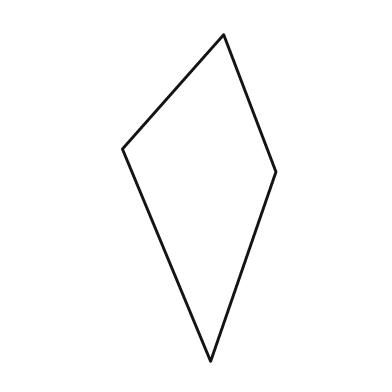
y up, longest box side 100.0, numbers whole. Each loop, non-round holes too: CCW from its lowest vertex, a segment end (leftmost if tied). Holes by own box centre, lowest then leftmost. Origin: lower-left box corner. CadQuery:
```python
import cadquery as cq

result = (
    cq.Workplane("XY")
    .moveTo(27.0, 0.0)
    .lineTo(47.0, 58.0)
    .lineTo(31.0, 100.0)
    .lineTo(0.0, 65.0)
    .close()
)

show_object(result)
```